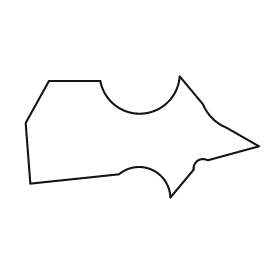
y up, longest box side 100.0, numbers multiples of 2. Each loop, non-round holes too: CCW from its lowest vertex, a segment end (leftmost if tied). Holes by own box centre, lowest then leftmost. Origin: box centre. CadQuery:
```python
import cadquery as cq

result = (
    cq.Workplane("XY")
    .moveTo(12.0, -26.0)
    .lineTo(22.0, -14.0)
    .threePointArc((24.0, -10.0), (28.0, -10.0))
    .lineTo(50.0, -4.0)
    .lineTo(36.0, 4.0)
    .threePointArc((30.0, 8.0), (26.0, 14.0))
    .lineTo(16.0, 26.0)
    .threePointArc((0.0, 10.0), (-18.0, 24.0))
    .lineTo(-40.0, 24.0)
    .lineTo(-50.0, 6.0)
    .lineTo(-48.0, -20.0)
    .lineTo(-10.0, -16.0)
    .threePointArc((4.0, -14.0), (12.0, -26.0))
    .close()
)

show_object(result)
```